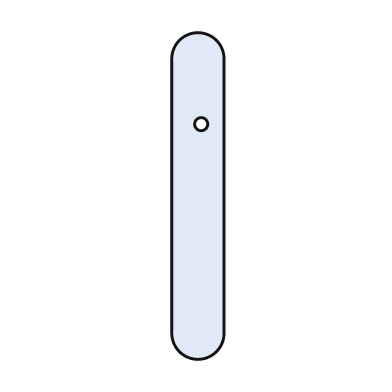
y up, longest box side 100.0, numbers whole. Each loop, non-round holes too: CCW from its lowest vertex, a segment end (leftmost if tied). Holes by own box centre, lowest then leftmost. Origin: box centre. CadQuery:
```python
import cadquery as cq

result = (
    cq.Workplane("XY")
    .moveTo(-8.0, -42.0)
    .threePointArc((0.0, -50.0), (8.0, -42.0))
    .lineTo(8.0, 42.0)
    .threePointArc((0.0, 50.0), (-8.0, 42.0))
    .close()
    .moveTo(1.0, 22.0)
    .circle(2.0)
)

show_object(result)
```